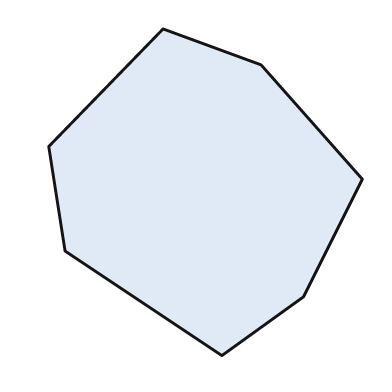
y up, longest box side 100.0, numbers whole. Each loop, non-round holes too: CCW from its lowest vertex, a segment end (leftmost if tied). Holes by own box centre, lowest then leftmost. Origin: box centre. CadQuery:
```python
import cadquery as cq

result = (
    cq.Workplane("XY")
    .moveTo(5.0, -50.0)
    .lineTo(30.0, -32.0)
    .lineTo(48.0, 4.0)
    .lineTo(17.0, 39.0)
    .lineTo(-13.0, 50.0)
    .lineTo(-48.0, 14.0)
    .lineTo(-43.0, -18.0)
    .close()
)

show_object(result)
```